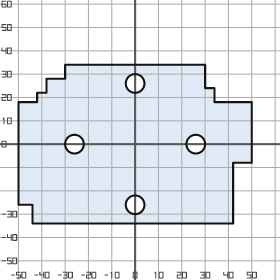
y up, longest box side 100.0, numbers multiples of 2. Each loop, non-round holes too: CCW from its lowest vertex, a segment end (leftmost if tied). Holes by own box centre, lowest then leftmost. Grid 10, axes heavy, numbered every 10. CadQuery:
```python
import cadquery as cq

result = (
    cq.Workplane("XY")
    .moveTo(-44.0, -34.0)
    .lineTo(42.0, -34.0)
    .lineTo(42.0, -8.0)
    .lineTo(50.0, -8.0)
    .lineTo(50.0, 18.0)
    .lineTo(34.0, 18.0)
    .lineTo(34.0, 24.0)
    .lineTo(30.0, 24.0)
    .lineTo(30.0, 34.0)
    .lineTo(-30.0, 34.0)
    .lineTo(-30.0, 28.0)
    .lineTo(-38.0, 28.0)
    .lineTo(-38.0, 22.0)
    .lineTo(-42.0, 22.0)
    .lineTo(-42.0, 18.0)
    .lineTo(-50.0, 18.0)
    .lineTo(-50.0, -26.0)
    .lineTo(-44.0, -26.0)
    .close()
    .moveTo(0.0, -26.0)
    .circle(4.0)
    .moveTo(-26.0, 0.0)
    .circle(4.0)
    .moveTo(26.0, 0.0)
    .circle(4.0)
    .moveTo(0.0, 26.0)
    .circle(4.0)
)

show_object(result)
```